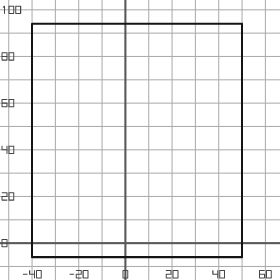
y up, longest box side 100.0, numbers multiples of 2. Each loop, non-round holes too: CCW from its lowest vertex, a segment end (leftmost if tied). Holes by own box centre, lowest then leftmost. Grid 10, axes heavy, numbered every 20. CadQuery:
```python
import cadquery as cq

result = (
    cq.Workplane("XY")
    .moveTo(-40.0, -6.0)
    .lineTo(50.0, -6.0)
    .lineTo(50.0, 94.0)
    .lineTo(-40.0, 94.0)
    .close()
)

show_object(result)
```